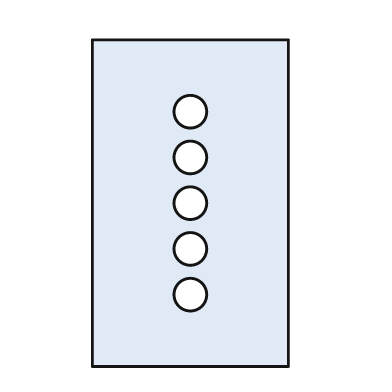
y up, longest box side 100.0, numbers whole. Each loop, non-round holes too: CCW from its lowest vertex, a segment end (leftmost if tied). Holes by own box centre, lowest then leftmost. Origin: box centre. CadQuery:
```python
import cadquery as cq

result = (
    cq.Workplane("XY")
    .moveTo(-30.0, -50.0)
    .lineTo(30.0, -50.0)
    .lineTo(30.0, 50.0)
    .lineTo(-30.0, 50.0)
    .close()
    .moveTo(0.0, -28.0)
    .circle(5.0)
    .moveTo(0.0, -14.0)
    .circle(5.0)
    .moveTo(0.0, 0.0)
    .circle(5.0)
    .moveTo(0.0, 14.0)
    .circle(5.0)
    .moveTo(0.0, 28.0)
    .circle(5.0)
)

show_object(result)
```